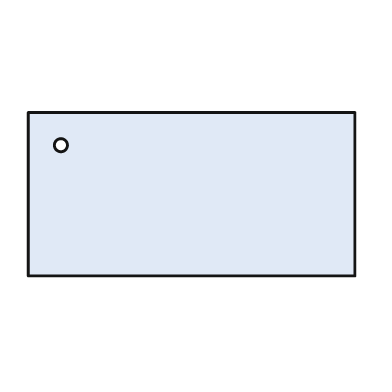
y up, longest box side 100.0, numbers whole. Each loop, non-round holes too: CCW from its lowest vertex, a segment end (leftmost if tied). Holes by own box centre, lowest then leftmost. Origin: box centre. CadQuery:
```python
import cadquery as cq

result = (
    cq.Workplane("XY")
    .moveTo(-50.0, -25.0)
    .lineTo(50.0, -25.0)
    .lineTo(50.0, 25.0)
    .lineTo(-50.0, 25.0)
    .close()
    .moveTo(-40.0, 15.0)
    .circle(2.0)
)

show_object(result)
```